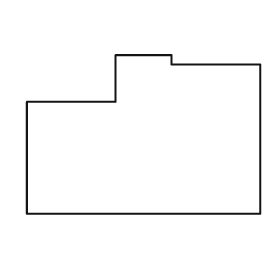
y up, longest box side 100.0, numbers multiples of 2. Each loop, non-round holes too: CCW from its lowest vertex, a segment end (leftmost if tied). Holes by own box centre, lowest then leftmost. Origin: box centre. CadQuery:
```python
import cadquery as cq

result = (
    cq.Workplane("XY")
    .moveTo(-50.0, -34.0)
    .lineTo(50.0, -34.0)
    .lineTo(50.0, 30.0)
    .lineTo(12.0, 30.0)
    .lineTo(12.0, 34.0)
    .lineTo(-12.0, 34.0)
    .lineTo(-12.0, 14.0)
    .lineTo(-50.0, 14.0)
    .close()
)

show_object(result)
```